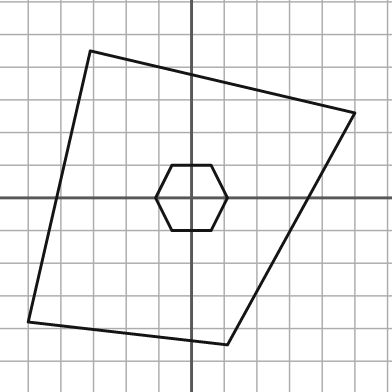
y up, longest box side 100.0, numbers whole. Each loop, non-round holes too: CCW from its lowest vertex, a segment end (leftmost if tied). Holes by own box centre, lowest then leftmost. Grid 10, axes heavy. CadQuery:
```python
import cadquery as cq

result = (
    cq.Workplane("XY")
    .moveTo(11.0, -45.0)
    .lineTo(50.0, 26.0)
    .lineTo(-31.0, 45.0)
    .lineTo(-50.0, -38.0)
    .close()
    .moveTo(-6.0, -10.0)
    .lineTo(6.0, -10.0)
    .lineTo(11.0, 0.0)
    .lineTo(6.0, 10.0)
    .lineTo(-6.0, 10.0)
    .lineTo(-11.0, 0.0)
    .close()
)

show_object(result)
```